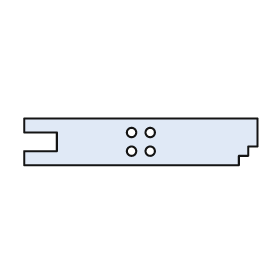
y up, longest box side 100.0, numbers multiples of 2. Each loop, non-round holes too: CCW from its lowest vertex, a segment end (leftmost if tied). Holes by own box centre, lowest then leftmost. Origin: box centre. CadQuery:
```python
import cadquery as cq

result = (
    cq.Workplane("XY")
    .moveTo(-50.0, -10.0)
    .lineTo(42.0, -10.0)
    .lineTo(42.0, -6.0)
    .lineTo(46.0, -6.0)
    .lineTo(46.0, -2.0)
    .lineTo(50.0, -2.0)
    .lineTo(50.0, 10.0)
    .lineTo(-50.0, 10.0)
    .lineTo(-50.0, 4.0)
    .lineTo(-36.0, 4.0)
    .lineTo(-36.0, -4.0)
    .lineTo(-50.0, -4.0)
    .close()
    .moveTo(-4.0, -4.0)
    .circle(2.0)
    .moveTo(4.0, -4.0)
    .circle(2.0)
    .moveTo(-4.0, 4.0)
    .circle(2.0)
    .moveTo(4.0, 4.0)
    .circle(2.0)
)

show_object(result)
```